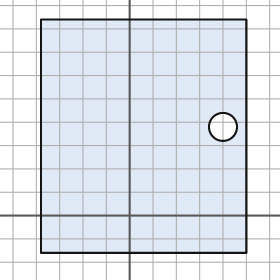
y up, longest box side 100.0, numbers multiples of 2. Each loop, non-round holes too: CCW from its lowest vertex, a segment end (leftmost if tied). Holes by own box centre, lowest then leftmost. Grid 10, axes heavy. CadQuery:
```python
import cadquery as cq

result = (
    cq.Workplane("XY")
    .moveTo(-38.0, -16.0)
    .lineTo(50.0, -16.0)
    .lineTo(50.0, 84.0)
    .lineTo(-38.0, 84.0)
    .close()
    .moveTo(40.0, 38.0)
    .circle(6.0)
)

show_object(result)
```